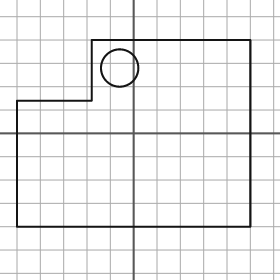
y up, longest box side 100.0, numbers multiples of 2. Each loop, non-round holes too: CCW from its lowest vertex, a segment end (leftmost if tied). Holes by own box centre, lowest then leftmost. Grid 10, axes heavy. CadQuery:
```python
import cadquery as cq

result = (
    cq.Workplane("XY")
    .moveTo(-50.0, -40.0)
    .lineTo(50.0, -40.0)
    .lineTo(50.0, 40.0)
    .lineTo(-18.0, 40.0)
    .lineTo(-18.0, 14.0)
    .lineTo(-50.0, 14.0)
    .close()
    .moveTo(-6.0, 28.0)
    .circle(8.0)
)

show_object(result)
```